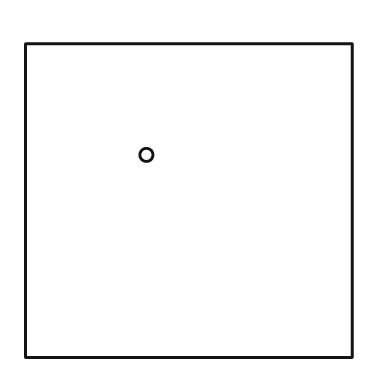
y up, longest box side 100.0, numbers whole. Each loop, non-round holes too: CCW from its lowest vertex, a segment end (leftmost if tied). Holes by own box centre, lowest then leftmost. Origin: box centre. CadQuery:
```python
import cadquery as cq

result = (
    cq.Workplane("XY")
    .moveTo(-50.0, -48.0)
    .lineTo(50.0, -48.0)
    .lineTo(50.0, 48.0)
    .lineTo(-50.0, 48.0)
    .close()
    .moveTo(-13.0, 14.0)
    .circle(2.0)
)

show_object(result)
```